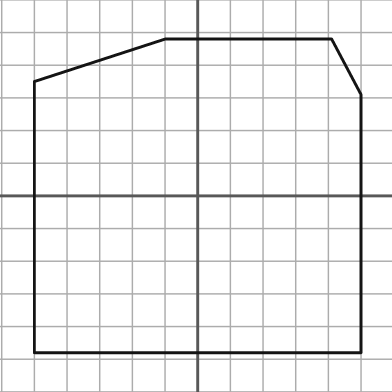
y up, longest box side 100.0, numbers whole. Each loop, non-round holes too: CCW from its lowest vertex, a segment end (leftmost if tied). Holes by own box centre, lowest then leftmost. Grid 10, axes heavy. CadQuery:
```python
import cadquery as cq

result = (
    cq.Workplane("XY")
    .moveTo(-50.0, -48.0)
    .lineTo(50.0, -48.0)
    .lineTo(50.0, 31.0)
    .lineTo(41.0, 48.0)
    .lineTo(-10.0, 48.0)
    .lineTo(-50.0, 35.0)
    .close()
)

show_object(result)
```